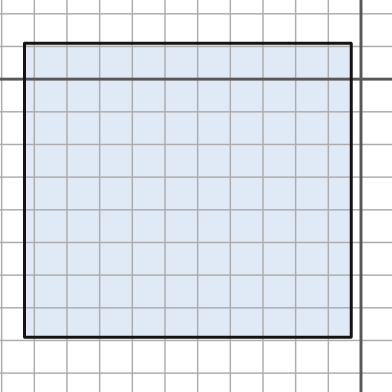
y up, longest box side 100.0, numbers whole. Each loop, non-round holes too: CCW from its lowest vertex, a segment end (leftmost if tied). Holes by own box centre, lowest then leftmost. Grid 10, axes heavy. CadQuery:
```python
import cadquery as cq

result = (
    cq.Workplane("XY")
    .moveTo(-103.0, -79.0)
    .lineTo(-3.0, -79.0)
    .lineTo(-3.0, 11.0)
    .lineTo(-103.0, 11.0)
    .close()
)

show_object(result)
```